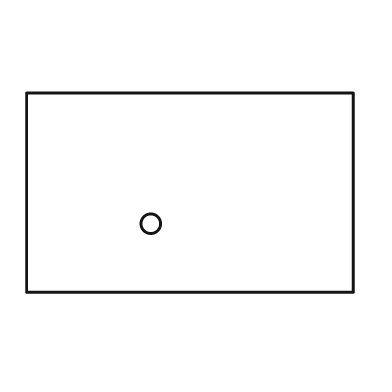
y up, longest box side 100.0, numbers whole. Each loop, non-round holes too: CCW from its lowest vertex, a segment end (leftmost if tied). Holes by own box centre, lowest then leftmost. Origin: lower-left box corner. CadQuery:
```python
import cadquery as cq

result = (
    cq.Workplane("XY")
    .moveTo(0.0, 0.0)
    .lineTo(100.0, 0.0)
    .lineTo(100.0, 61.0)
    .lineTo(0.0, 61.0)
    .close()
    .moveTo(38.0, 21.0)
    .circle(3.0)
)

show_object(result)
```